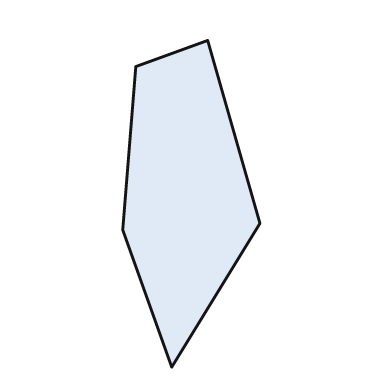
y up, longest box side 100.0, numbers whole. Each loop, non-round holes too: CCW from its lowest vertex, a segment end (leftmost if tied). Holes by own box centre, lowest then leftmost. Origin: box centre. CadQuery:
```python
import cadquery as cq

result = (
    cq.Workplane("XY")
    .moveTo(-6.0, -50.0)
    .lineTo(21.0, -6.0)
    .lineTo(5.0, 50.0)
    .lineTo(-17.0, 42.0)
    .lineTo(-21.0, -8.0)
    .close()
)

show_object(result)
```